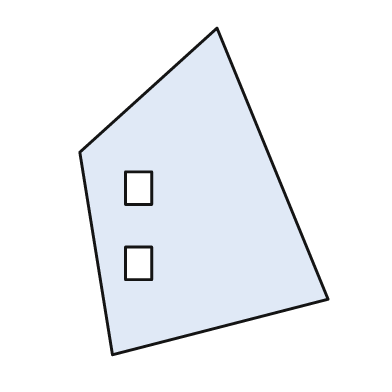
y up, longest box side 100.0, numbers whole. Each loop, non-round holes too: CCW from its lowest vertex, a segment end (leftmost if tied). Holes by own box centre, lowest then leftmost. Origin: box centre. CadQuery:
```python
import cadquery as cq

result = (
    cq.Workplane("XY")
    .moveTo(-28.0, -50.0)
    .lineTo(38.0, -33.0)
    .lineTo(4.0, 50.0)
    .lineTo(-38.0, 12.0)
    .close()
    .moveTo(-24.0, -27.0)
    .lineTo(-16.0, -27.0)
    .lineTo(-16.0, -17.0)
    .lineTo(-24.0, -17.0)
    .close()
    .moveTo(-24.0, -4.0)
    .lineTo(-16.0, -4.0)
    .lineTo(-16.0, 6.0)
    .lineTo(-24.0, 6.0)
    .close()
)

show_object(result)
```